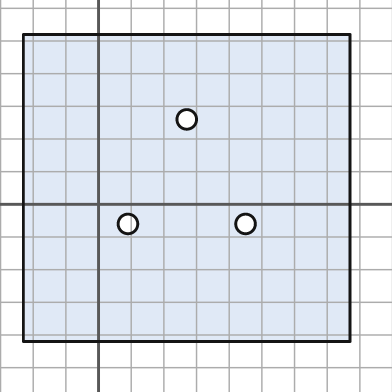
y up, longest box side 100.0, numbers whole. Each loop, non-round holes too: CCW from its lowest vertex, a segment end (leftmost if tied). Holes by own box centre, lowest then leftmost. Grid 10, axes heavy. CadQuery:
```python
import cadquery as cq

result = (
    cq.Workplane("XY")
    .moveTo(-23.0, -42.0)
    .lineTo(77.0, -42.0)
    .lineTo(77.0, 52.0)
    .lineTo(-23.0, 52.0)
    .close()
    .moveTo(9.0, -6.0)
    .circle(3.0)
    .moveTo(45.0, -6.0)
    .circle(3.0)
    .moveTo(27.0, 26.0)
    .circle(3.0)
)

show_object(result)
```